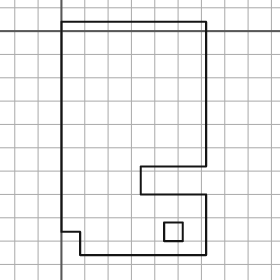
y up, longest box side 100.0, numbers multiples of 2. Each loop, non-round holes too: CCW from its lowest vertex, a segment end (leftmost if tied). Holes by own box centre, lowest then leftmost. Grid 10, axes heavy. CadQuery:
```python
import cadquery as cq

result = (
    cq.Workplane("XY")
    .moveTo(8.0, -96.0)
    .lineTo(62.0, -96.0)
    .lineTo(62.0, -70.0)
    .lineTo(34.0, -70.0)
    .lineTo(34.0, -58.0)
    .lineTo(62.0, -58.0)
    .lineTo(62.0, 4.0)
    .lineTo(0.0, 4.0)
    .lineTo(0.0, -86.0)
    .lineTo(8.0, -86.0)
    .close()
    .moveTo(44.0, -90.0)
    .lineTo(52.0, -90.0)
    .lineTo(52.0, -82.0)
    .lineTo(44.0, -82.0)
    .close()
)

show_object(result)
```